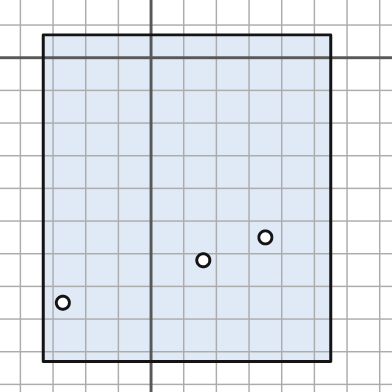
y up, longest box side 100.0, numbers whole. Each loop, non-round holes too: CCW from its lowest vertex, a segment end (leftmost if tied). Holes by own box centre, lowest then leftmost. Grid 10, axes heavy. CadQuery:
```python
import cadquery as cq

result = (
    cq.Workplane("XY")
    .moveTo(-33.0, -93.0)
    .lineTo(55.0, -93.0)
    .lineTo(55.0, 7.0)
    .lineTo(-33.0, 7.0)
    .close()
    .moveTo(-27.0, -75.0)
    .circle(2.0)
    .moveTo(16.0, -62.0)
    .circle(2.0)
    .moveTo(35.0, -55.0)
    .circle(2.0)
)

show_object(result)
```